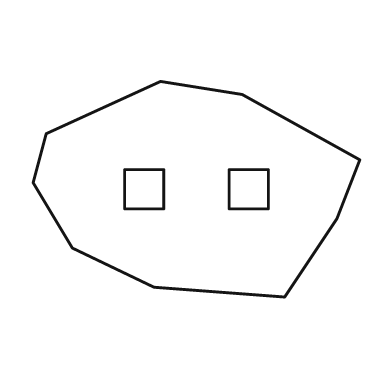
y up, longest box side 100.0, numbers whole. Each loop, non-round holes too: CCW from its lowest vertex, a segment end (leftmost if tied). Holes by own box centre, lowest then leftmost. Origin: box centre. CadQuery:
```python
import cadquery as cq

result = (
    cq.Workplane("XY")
    .moveTo(27.0, -33.0)
    .lineTo(43.0, -9.0)
    .lineTo(50.0, 9.0)
    .lineTo(14.0, 29.0)
    .lineTo(-11.0, 33.0)
    .lineTo(-46.0, 17.0)
    .lineTo(-50.0, 2.0)
    .lineTo(-38.0, -18.0)
    .lineTo(-13.0, -30.0)
    .close()
    .moveTo(-22.0, -6.0)
    .lineTo(-10.0, -6.0)
    .lineTo(-10.0, 6.0)
    .lineTo(-22.0, 6.0)
    .close()
    .moveTo(10.0, -6.0)
    .lineTo(22.0, -6.0)
    .lineTo(22.0, 6.0)
    .lineTo(10.0, 6.0)
    .close()
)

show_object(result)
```